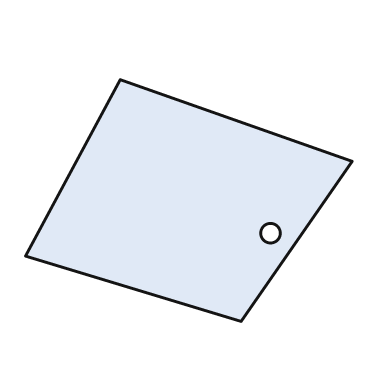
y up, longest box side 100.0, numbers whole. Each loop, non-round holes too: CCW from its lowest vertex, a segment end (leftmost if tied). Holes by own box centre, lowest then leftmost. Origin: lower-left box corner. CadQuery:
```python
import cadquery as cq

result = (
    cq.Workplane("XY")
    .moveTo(66.0, 0.0)
    .lineTo(100.0, 49.0)
    .lineTo(29.0, 74.0)
    .lineTo(0.0, 20.0)
    .close()
    .moveTo(75.0, 27.0)
    .circle(3.0)
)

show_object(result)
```